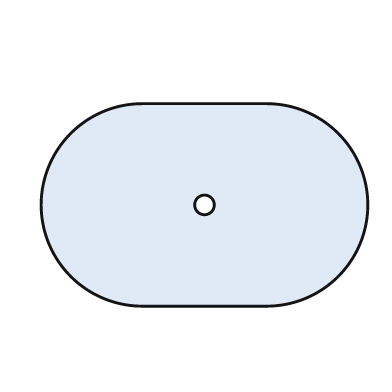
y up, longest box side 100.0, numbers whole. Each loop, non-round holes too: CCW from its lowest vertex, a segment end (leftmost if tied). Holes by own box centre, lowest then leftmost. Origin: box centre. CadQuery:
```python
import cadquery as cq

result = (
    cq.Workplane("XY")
    .moveTo(-19.0, -31.0)
    .lineTo(19.0, -31.0)
    .threePointArc((50.0, 0.0), (19.0, 31.0))
    .lineTo(-19.0, 31.0)
    .threePointArc((-50.0, 0.0), (-19.0, -31.0))
    .close()
    .moveTo(0.0, 0.0)
    .circle(3.0)
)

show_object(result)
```